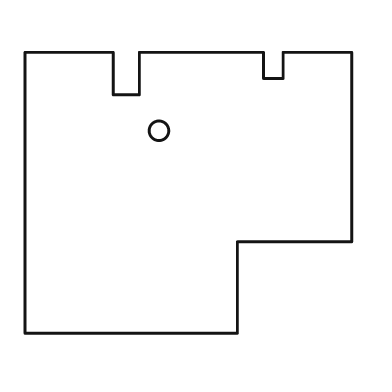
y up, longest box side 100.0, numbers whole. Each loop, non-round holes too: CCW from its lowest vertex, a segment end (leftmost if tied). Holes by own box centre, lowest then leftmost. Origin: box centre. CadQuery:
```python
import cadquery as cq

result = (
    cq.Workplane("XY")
    .moveTo(-50.0, -43.0)
    .lineTo(15.0, -43.0)
    .lineTo(15.0, -15.0)
    .lineTo(50.0, -15.0)
    .lineTo(50.0, 43.0)
    .lineTo(29.0, 43.0)
    .lineTo(29.0, 35.0)
    .lineTo(23.0, 35.0)
    .lineTo(23.0, 43.0)
    .lineTo(-15.0, 43.0)
    .lineTo(-15.0, 30.0)
    .lineTo(-23.0, 30.0)
    .lineTo(-23.0, 43.0)
    .lineTo(-50.0, 43.0)
    .close()
    .moveTo(-9.0, 19.0)
    .circle(3.0)
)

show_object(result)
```